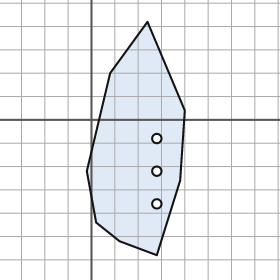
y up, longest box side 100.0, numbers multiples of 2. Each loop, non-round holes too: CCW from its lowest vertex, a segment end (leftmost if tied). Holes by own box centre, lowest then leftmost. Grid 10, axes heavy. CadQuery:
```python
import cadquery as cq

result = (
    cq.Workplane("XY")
    .moveTo(28.0, -58.0)
    .lineTo(38.0, -26.0)
    .lineTo(40.0, 4.0)
    .lineTo(24.0, 42.0)
    .lineTo(8.0, 20.0)
    .lineTo(-2.0, -22.0)
    .lineTo(2.0, -44.0)
    .lineTo(12.0, -52.0)
    .close()
    .moveTo(28.0, -36.0)
    .circle(2.0)
    .moveTo(28.0, -22.0)
    .circle(2.0)
    .moveTo(28.0, -8.0)
    .circle(2.0)
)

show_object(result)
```